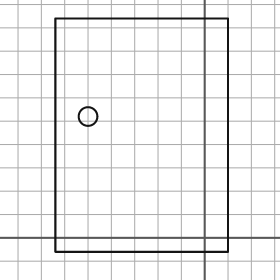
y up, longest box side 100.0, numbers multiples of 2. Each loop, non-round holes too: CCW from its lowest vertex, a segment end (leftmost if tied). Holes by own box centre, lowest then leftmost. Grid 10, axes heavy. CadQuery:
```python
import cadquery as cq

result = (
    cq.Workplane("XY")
    .moveTo(-64.0, -6.0)
    .lineTo(10.0, -6.0)
    .lineTo(10.0, 94.0)
    .lineTo(-64.0, 94.0)
    .close()
    .moveTo(-50.0, 52.0)
    .circle(4.0)
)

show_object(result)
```